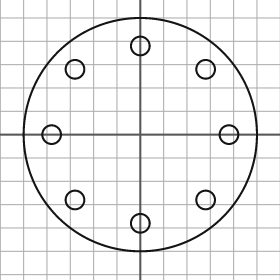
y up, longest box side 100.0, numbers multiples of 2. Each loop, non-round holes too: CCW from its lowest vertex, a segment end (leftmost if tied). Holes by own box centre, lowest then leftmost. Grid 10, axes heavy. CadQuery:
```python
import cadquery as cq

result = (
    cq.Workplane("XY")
    .moveTo(0.0, 0.0)
    .circle(50.0)
    .moveTo(0.0, -38.0)
    .circle(4.0)
    .moveTo(-28.0, -28.0)
    .circle(4.0)
    .moveTo(28.0, -28.0)
    .circle(4.0)
    .moveTo(-38.0, 0.0)
    .circle(4.0)
    .moveTo(38.0, 0.0)
    .circle(4.0)
    .moveTo(-28.0, 28.0)
    .circle(4.0)
    .moveTo(28.0, 28.0)
    .circle(4.0)
    .moveTo(0.0, 38.0)
    .circle(4.0)
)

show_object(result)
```